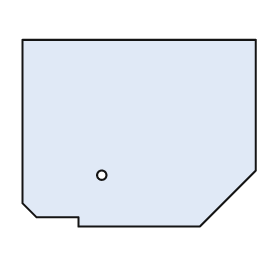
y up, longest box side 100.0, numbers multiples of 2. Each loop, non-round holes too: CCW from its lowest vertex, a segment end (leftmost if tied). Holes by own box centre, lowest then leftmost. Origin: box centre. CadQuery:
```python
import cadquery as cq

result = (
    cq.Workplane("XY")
    .moveTo(-26.0, -40.0)
    .lineTo(26.0, -40.0)
    .lineTo(50.0, -16.0)
    .lineTo(50.0, 40.0)
    .lineTo(-50.0, 40.0)
    .lineTo(-50.0, -30.0)
    .lineTo(-44.0, -36.0)
    .lineTo(-26.0, -36.0)
    .close()
    .moveTo(-16.0, -18.0)
    .circle(2.0)
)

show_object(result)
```